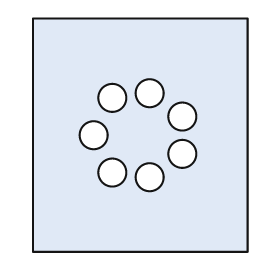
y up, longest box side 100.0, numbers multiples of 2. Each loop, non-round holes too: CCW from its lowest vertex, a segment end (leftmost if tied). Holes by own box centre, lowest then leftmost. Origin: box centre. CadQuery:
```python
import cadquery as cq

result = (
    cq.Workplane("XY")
    .moveTo(-46.0, -50.0)
    .lineTo(46.0, -50.0)
    .lineTo(46.0, 50.0)
    .lineTo(-46.0, 50.0)
    .close()
    .moveTo(4.0, -18.0)
    .circle(6.0)
    .moveTo(-12.0, -16.0)
    .circle(6.0)
    .moveTo(18.0, -8.0)
    .circle(6.0)
    .moveTo(-20.0, 0.0)
    .circle(6.0)
    .moveTo(18.0, 8.0)
    .circle(6.0)
    .moveTo(-12.0, 16.0)
    .circle(6.0)
    .moveTo(4.0, 18.0)
    .circle(6.0)
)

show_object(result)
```